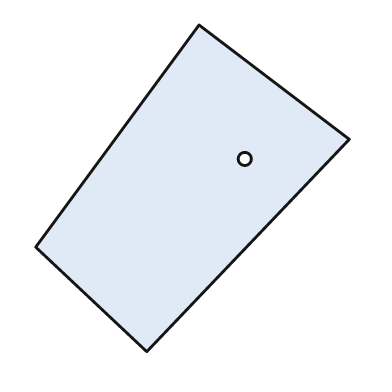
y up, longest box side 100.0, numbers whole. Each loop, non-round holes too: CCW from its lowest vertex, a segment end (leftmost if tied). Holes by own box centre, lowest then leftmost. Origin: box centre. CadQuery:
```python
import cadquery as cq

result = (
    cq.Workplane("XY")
    .moveTo(-14.0, -50.0)
    .lineTo(48.0, 15.0)
    .lineTo(2.0, 50.0)
    .lineTo(-48.0, -18.0)
    .close()
    .moveTo(16.0, 9.0)
    .circle(2.0)
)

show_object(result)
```